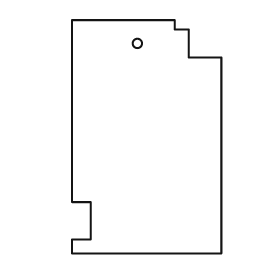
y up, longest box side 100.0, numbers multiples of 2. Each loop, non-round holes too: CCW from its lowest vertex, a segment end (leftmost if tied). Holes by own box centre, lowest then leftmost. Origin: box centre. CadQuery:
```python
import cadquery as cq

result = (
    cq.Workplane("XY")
    .moveTo(-32.0, -50.0)
    .lineTo(32.0, -50.0)
    .lineTo(32.0, 34.0)
    .lineTo(18.0, 34.0)
    .lineTo(18.0, 46.0)
    .lineTo(12.0, 46.0)
    .lineTo(12.0, 50.0)
    .lineTo(-32.0, 50.0)
    .lineTo(-32.0, -28.0)
    .lineTo(-24.0, -28.0)
    .lineTo(-24.0, -44.0)
    .lineTo(-32.0, -44.0)
    .close()
    .moveTo(-4.0, 40.0)
    .circle(2.0)
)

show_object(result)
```